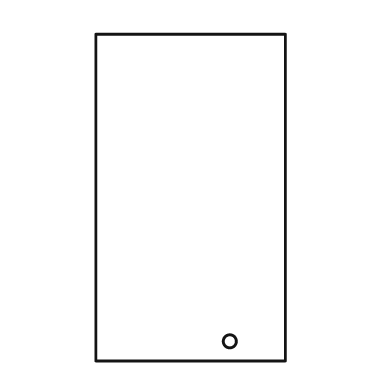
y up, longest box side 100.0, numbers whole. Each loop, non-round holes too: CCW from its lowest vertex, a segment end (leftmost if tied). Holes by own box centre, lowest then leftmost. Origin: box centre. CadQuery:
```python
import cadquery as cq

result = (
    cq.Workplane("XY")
    .moveTo(-29.0, -50.0)
    .lineTo(29.0, -50.0)
    .lineTo(29.0, 50.0)
    .lineTo(-29.0, 50.0)
    .close()
    .moveTo(12.0, -44.0)
    .circle(2.0)
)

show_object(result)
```